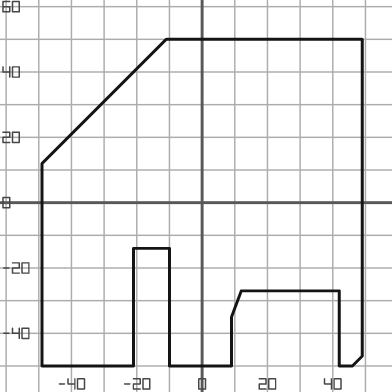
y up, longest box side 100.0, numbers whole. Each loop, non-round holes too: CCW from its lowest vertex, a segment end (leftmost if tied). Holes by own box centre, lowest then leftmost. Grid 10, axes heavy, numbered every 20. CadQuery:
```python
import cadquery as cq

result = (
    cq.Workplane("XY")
    .moveTo(-49.0, -50.0)
    .lineTo(-21.0, -50.0)
    .lineTo(-21.0, -14.0)
    .lineTo(-10.0, -14.0)
    .lineTo(-10.0, -50.0)
    .lineTo(9.0, -50.0)
    .lineTo(9.0, -35.0)
    .lineTo(12.0, -27.0)
    .lineTo(42.0, -27.0)
    .lineTo(42.0, -50.0)
    .lineTo(46.0, -50.0)
    .lineTo(49.0, -47.0)
    .lineTo(49.0, 50.0)
    .lineTo(-11.0, 50.0)
    .lineTo(-49.0, 12.0)
    .close()
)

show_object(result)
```